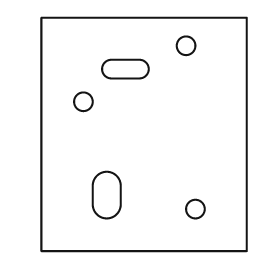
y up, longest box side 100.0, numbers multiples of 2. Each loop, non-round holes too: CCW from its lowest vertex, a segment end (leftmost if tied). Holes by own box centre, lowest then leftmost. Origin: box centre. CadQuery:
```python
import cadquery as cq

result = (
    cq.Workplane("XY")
    .moveTo(-44.0, -50.0)
    .lineTo(44.0, -50.0)
    .lineTo(44.0, 50.0)
    .lineTo(-44.0, 50.0)
    .close()
    .moveTo(22.0, -32.0)
    .circle(4.0)
    .moveTo(-22.0, -30.0)
    .threePointArc((-16.0, -36.0), (-10.0, -30.0))
    .lineTo(-10.0, -22.0)
    .threePointArc((-16.0, -16.0), (-22.0, -22.0))
    .close()
    .moveTo(-26.0, 14.0)
    .circle(4.0)
    .moveTo(-14.0, 24.0)
    .lineTo(-2.0, 24.0)
    .threePointArc((2.0, 28.0), (-2.0, 32.0))
    .lineTo(-14.0, 32.0)
    .threePointArc((-18.0, 28.0), (-14.0, 24.0))
    .close()
    .moveTo(18.0, 38.0)
    .circle(4.0)
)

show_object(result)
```